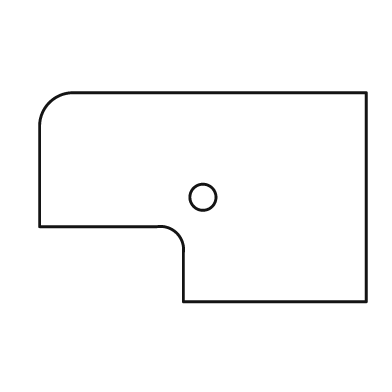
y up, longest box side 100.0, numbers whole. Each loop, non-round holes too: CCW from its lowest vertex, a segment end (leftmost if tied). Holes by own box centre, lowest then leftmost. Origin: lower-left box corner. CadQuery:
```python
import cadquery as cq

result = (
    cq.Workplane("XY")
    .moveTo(44.0, 0.0)
    .lineTo(100.0, 0.0)
    .lineTo(100.0, 64.0)
    .lineTo(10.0, 64.0)
    .threePointArc((3.0, 61.0), (0.0, 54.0))
    .lineTo(0.0, 23.0)
    .lineTo(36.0, 23.0)
    .threePointArc((42.0, 21.0), (44.0, 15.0))
    .close()
    .moveTo(50.0, 32.0)
    .circle(4.0)
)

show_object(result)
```